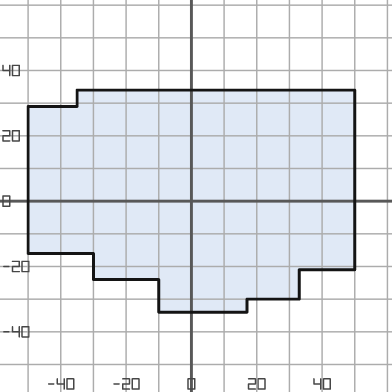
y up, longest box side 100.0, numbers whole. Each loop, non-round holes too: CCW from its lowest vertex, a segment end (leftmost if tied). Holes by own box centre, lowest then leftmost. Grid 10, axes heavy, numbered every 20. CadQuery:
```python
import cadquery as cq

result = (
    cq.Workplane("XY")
    .moveTo(-10.0, -34.0)
    .lineTo(17.0, -34.0)
    .lineTo(17.0, -30.0)
    .lineTo(33.0, -30.0)
    .lineTo(33.0, -21.0)
    .lineTo(50.0, -21.0)
    .lineTo(50.0, 34.0)
    .lineTo(-35.0, 34.0)
    .lineTo(-35.0, 29.0)
    .lineTo(-50.0, 29.0)
    .lineTo(-50.0, -16.0)
    .lineTo(-30.0, -16.0)
    .lineTo(-30.0, -24.0)
    .lineTo(-10.0, -24.0)
    .close()
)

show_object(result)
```